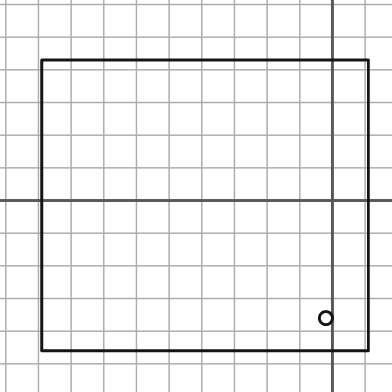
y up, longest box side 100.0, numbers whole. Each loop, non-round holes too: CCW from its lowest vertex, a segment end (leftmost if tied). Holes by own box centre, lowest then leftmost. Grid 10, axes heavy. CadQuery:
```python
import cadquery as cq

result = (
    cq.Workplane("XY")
    .moveTo(-89.0, -46.0)
    .lineTo(11.0, -46.0)
    .lineTo(11.0, 43.0)
    .lineTo(-89.0, 43.0)
    .close()
    .moveTo(-2.0, -36.0)
    .circle(2.0)
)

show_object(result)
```